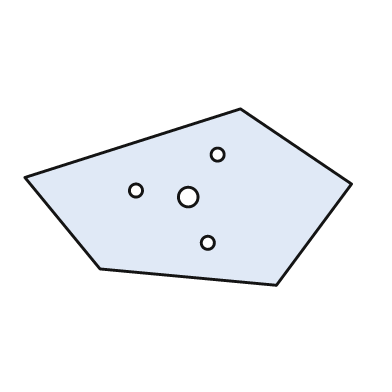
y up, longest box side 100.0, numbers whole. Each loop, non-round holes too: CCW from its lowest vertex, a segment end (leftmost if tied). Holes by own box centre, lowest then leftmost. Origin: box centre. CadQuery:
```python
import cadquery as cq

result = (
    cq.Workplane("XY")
    .moveTo(27.0, -27.0)
    .lineTo(50.0, 4.0)
    .lineTo(16.0, 27.0)
    .lineTo(-50.0, 6.0)
    .lineTo(-27.0, -22.0)
    .close()
    .moveTo(6.0, -14.0)
    .circle(2.0)
    .moveTo(0.0, 0.0)
    .circle(3.0)
    .moveTo(-16.0, 2.0)
    .circle(2.0)
    .moveTo(9.0, 13.0)
    .circle(2.0)
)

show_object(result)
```